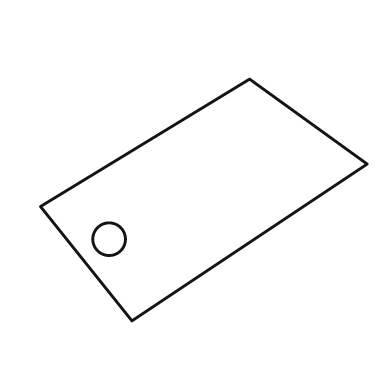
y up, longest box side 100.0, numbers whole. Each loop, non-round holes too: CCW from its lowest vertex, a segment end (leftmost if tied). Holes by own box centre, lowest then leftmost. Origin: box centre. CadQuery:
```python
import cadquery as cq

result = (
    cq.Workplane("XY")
    .moveTo(-22.0, -37.0)
    .lineTo(50.0, 11.0)
    .lineTo(14.0, 37.0)
    .lineTo(-50.0, -2.0)
    .close()
    .moveTo(-29.0, -12.0)
    .circle(5.0)
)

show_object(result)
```